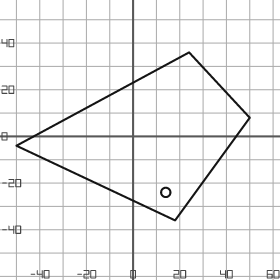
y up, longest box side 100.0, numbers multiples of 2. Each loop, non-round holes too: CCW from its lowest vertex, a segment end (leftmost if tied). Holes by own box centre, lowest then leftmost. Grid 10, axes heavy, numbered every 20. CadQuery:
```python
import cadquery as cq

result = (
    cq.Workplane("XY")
    .moveTo(18.0, -36.0)
    .lineTo(50.0, 8.0)
    .lineTo(24.0, 36.0)
    .lineTo(-50.0, -4.0)
    .close()
    .moveTo(14.0, -24.0)
    .circle(2.0)
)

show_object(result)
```